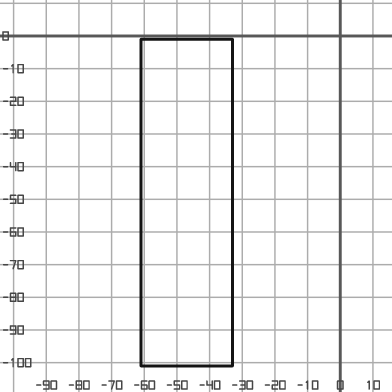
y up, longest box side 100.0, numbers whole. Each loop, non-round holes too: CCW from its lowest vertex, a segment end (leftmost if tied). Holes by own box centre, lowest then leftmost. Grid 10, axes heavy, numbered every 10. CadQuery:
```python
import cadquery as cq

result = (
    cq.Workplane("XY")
    .moveTo(-61.0, -101.0)
    .lineTo(-33.0, -101.0)
    .lineTo(-33.0, -1.0)
    .lineTo(-61.0, -1.0)
    .close()
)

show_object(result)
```